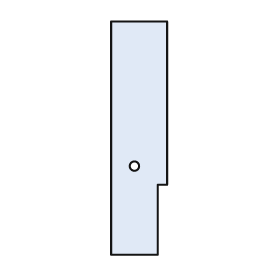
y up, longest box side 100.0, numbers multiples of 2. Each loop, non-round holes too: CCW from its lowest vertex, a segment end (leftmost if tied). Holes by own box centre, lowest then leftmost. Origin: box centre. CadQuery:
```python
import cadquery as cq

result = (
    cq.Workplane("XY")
    .moveTo(-12.0, -50.0)
    .lineTo(8.0, -50.0)
    .lineTo(8.0, -20.0)
    .lineTo(12.0, -20.0)
    .lineTo(12.0, 50.0)
    .lineTo(-12.0, 50.0)
    .close()
    .moveTo(-2.0, -12.0)
    .circle(2.0)
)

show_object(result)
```